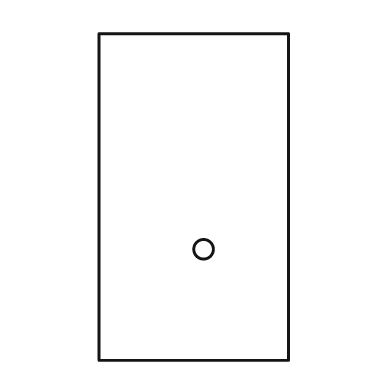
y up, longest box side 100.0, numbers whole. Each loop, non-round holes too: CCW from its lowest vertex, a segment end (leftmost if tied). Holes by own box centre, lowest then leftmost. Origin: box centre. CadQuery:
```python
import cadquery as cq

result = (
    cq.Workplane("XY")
    .moveTo(-29.0, -50.0)
    .lineTo(29.0, -50.0)
    .lineTo(29.0, 50.0)
    .lineTo(-29.0, 50.0)
    .close()
    .moveTo(3.0, -16.0)
    .circle(3.0)
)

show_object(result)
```